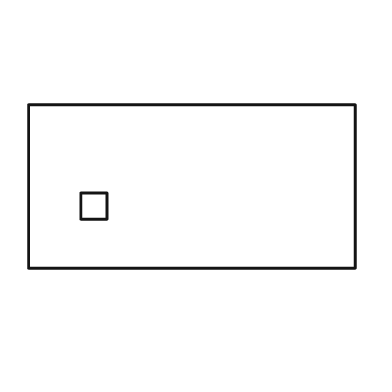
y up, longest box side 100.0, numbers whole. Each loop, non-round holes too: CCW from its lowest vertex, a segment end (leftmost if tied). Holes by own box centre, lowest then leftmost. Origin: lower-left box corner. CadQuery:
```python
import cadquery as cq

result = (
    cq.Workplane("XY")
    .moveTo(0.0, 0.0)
    .lineTo(100.0, 0.0)
    .lineTo(100.0, 50.0)
    .lineTo(0.0, 50.0)
    .close()
    .moveTo(16.0, 15.0)
    .lineTo(24.0, 15.0)
    .lineTo(24.0, 23.0)
    .lineTo(16.0, 23.0)
    .close()
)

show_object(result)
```